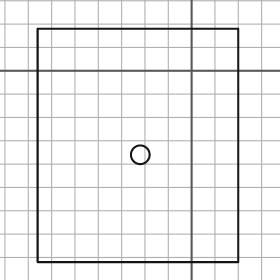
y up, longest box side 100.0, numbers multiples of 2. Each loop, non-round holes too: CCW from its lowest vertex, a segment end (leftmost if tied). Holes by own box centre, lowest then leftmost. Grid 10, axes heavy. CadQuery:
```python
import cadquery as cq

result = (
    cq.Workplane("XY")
    .moveTo(-66.0, -82.0)
    .lineTo(20.0, -82.0)
    .lineTo(20.0, 18.0)
    .lineTo(-66.0, 18.0)
    .close()
    .moveTo(-22.0, -36.0)
    .circle(4.0)
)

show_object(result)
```